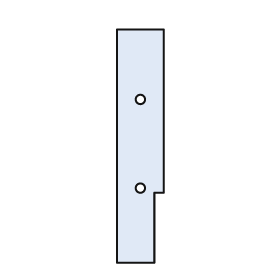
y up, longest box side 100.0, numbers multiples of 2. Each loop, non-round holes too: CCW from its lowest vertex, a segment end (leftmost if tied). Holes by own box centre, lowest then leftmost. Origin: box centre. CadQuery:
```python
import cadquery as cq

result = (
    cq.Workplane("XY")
    .moveTo(-10.0, -50.0)
    .lineTo(6.0, -50.0)
    .lineTo(6.0, -20.0)
    .lineTo(10.0, -20.0)
    .lineTo(10.0, 50.0)
    .lineTo(-10.0, 50.0)
    .close()
    .moveTo(0.0, -18.0)
    .circle(2.0)
    .moveTo(0.0, 20.0)
    .circle(2.0)
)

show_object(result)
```